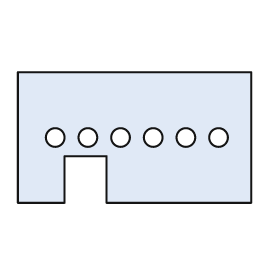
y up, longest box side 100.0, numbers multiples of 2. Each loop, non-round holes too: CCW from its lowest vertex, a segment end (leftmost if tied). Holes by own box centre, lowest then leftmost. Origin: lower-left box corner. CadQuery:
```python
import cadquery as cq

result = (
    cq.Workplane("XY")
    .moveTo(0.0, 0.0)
    .lineTo(20.0, 0.0)
    .lineTo(20.0, 20.0)
    .lineTo(38.0, 20.0)
    .lineTo(38.0, 0.0)
    .lineTo(100.0, 0.0)
    .lineTo(100.0, 56.0)
    .lineTo(0.0, 56.0)
    .close()
    .moveTo(16.0, 28.0)
    .circle(4.0)
    .moveTo(30.0, 28.0)
    .circle(4.0)
    .moveTo(44.0, 28.0)
    .circle(4.0)
    .moveTo(58.0, 28.0)
    .circle(4.0)
    .moveTo(72.0, 28.0)
    .circle(4.0)
    .moveTo(86.0, 28.0)
    .circle(4.0)
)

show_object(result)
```